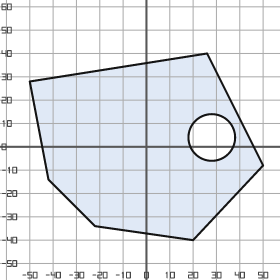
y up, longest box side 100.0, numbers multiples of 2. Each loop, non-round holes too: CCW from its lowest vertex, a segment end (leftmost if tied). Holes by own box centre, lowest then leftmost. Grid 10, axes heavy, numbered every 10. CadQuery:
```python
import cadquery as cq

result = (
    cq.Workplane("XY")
    .moveTo(20.0, -40.0)
    .lineTo(50.0, -8.0)
    .lineTo(26.0, 40.0)
    .lineTo(-50.0, 28.0)
    .lineTo(-42.0, -14.0)
    .lineTo(-22.0, -34.0)
    .close()
    .moveTo(28.0, 4.0)
    .circle(10.0)
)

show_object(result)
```